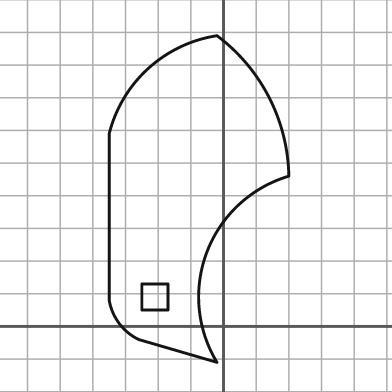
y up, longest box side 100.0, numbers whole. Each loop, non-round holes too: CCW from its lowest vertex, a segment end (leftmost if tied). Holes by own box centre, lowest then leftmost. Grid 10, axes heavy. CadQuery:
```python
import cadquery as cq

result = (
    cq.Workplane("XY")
    .moveTo(-2.0, -11.0)
    .threePointArc((-5.0, 23.0), (20.0, 46.0))
    .threePointArc((14.0, 70.0), (-2.0, 89.0))
    .threePointArc((-23.0, 79.0), (-35.0, 59.0))
    .lineTo(-35.0, 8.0)
    .threePointArc((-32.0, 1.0), (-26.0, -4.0))
    .close()
    .moveTo(-25.0, 5.0)
    .lineTo(-17.0, 5.0)
    .lineTo(-17.0, 13.0)
    .lineTo(-25.0, 13.0)
    .close()
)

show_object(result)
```